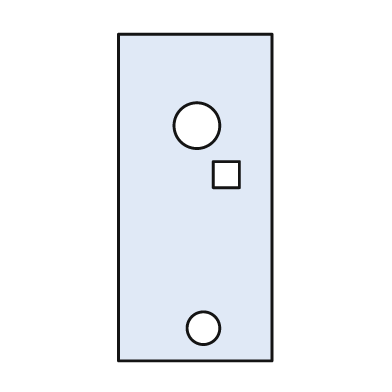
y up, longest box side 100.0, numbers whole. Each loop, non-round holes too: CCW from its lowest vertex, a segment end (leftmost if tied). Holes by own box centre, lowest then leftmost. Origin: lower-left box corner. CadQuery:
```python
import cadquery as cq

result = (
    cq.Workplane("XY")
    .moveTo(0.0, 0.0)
    .lineTo(47.0, 0.0)
    .lineTo(47.0, 100.0)
    .lineTo(0.0, 100.0)
    .close()
    .moveTo(26.0, 10.0)
    .circle(5.0)
    .moveTo(29.0, 53.0)
    .lineTo(37.0, 53.0)
    .lineTo(37.0, 61.0)
    .lineTo(29.0, 61.0)
    .close()
    .moveTo(24.0, 72.0)
    .circle(7.0)
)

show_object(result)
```